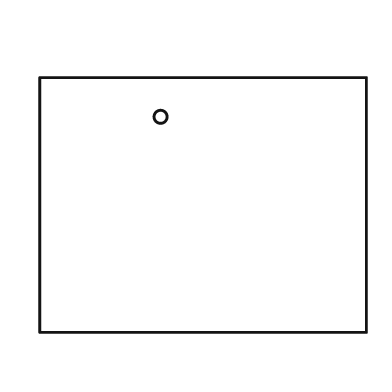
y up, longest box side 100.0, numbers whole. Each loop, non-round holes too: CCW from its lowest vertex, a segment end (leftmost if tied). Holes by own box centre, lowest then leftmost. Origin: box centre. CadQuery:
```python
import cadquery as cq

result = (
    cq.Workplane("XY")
    .moveTo(-50.0, -39.0)
    .lineTo(50.0, -39.0)
    .lineTo(50.0, 39.0)
    .lineTo(-50.0, 39.0)
    .close()
    .moveTo(-13.0, 27.0)
    .circle(2.0)
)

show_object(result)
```